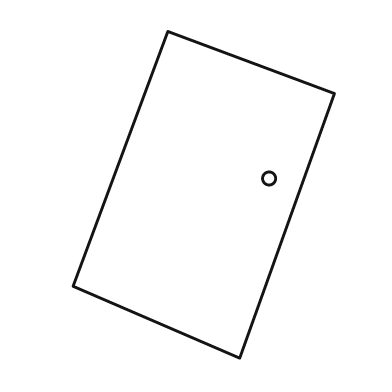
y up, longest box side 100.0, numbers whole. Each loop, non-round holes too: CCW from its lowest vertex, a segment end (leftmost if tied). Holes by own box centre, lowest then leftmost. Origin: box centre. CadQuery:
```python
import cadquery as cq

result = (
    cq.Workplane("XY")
    .moveTo(11.0, -50.0)
    .lineTo(40.0, 31.0)
    .lineTo(-11.0, 50.0)
    .lineTo(-40.0, -28.0)
    .close()
    .moveTo(20.0, 5.0)
    .circle(2.0)
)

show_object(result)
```